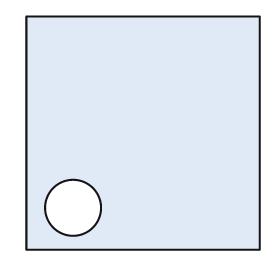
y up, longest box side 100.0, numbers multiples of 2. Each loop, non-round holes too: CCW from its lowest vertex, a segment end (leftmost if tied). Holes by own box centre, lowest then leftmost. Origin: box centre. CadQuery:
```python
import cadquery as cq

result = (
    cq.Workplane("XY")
    .moveTo(-50.0, -50.0)
    .lineTo(50.0, -50.0)
    .lineTo(50.0, 50.0)
    .lineTo(-50.0, 50.0)
    .close()
    .moveTo(-30.0, -32.0)
    .circle(12.0)
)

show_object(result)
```